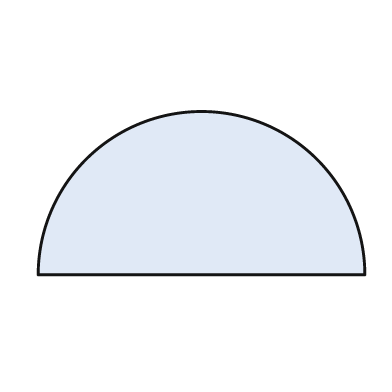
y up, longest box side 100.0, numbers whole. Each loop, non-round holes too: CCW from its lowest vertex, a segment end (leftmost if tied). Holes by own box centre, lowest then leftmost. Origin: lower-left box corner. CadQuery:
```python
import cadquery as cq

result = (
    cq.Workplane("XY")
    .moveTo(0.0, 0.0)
    .lineTo(100.0, 0.0)
    .threePointArc((50.0, 50.0), (0.0, 0.0))
    .close()
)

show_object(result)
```